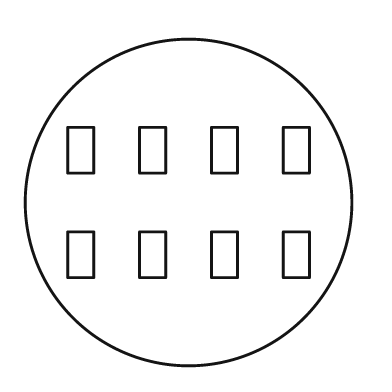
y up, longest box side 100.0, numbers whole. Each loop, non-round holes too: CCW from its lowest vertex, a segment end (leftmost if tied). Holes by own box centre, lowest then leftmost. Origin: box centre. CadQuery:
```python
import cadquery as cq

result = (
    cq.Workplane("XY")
    .moveTo(0.0, 0.0)
    .circle(50.0)
    .moveTo(-37.0, -23.0)
    .lineTo(-29.0, -23.0)
    .lineTo(-29.0, -9.0)
    .lineTo(-37.0, -9.0)
    .close()
    .moveTo(-15.0, -23.0)
    .lineTo(-7.0, -23.0)
    .lineTo(-7.0, -9.0)
    .lineTo(-15.0, -9.0)
    .close()
    .moveTo(7.0, -23.0)
    .lineTo(15.0, -23.0)
    .lineTo(15.0, -9.0)
    .lineTo(7.0, -9.0)
    .close()
    .moveTo(29.0, -23.0)
    .lineTo(37.0, -23.0)
    .lineTo(37.0, -9.0)
    .lineTo(29.0, -9.0)
    .close()
    .moveTo(-37.0, 9.0)
    .lineTo(-29.0, 9.0)
    .lineTo(-29.0, 23.0)
    .lineTo(-37.0, 23.0)
    .close()
    .moveTo(-15.0, 9.0)
    .lineTo(-7.0, 9.0)
    .lineTo(-7.0, 23.0)
    .lineTo(-15.0, 23.0)
    .close()
    .moveTo(7.0, 9.0)
    .lineTo(15.0, 9.0)
    .lineTo(15.0, 23.0)
    .lineTo(7.0, 23.0)
    .close()
    .moveTo(29.0, 9.0)
    .lineTo(37.0, 9.0)
    .lineTo(37.0, 23.0)
    .lineTo(29.0, 23.0)
    .close()
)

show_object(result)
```